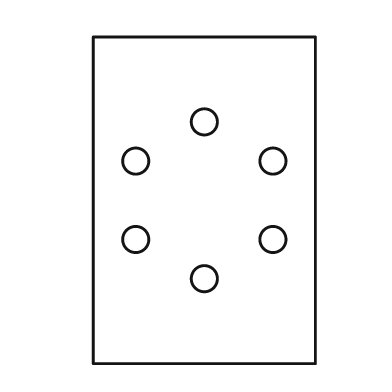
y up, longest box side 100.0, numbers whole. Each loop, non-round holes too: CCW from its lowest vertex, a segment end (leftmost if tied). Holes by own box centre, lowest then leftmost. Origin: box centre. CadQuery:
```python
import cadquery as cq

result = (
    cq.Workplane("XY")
    .moveTo(-34.0, -50.0)
    .lineTo(34.0, -50.0)
    .lineTo(34.0, 50.0)
    .lineTo(-34.0, 50.0)
    .close()
    .moveTo(0.0, -24.0)
    .circle(4.0)
    .moveTo(-21.0, -12.0)
    .circle(4.0)
    .moveTo(21.0, -12.0)
    .circle(4.0)
    .moveTo(-21.0, 12.0)
    .circle(4.0)
    .moveTo(21.0, 12.0)
    .circle(4.0)
    .moveTo(0.0, 24.0)
    .circle(4.0)
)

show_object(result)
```